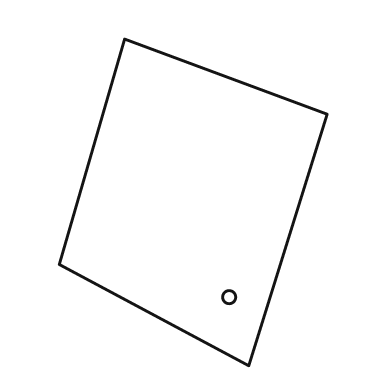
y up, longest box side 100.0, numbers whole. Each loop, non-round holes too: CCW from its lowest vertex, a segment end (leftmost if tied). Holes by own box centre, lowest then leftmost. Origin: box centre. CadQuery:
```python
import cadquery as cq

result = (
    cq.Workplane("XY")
    .moveTo(17.0, -50.0)
    .lineTo(41.0, 27.0)
    .lineTo(-21.0, 50.0)
    .lineTo(-41.0, -19.0)
    .close()
    .moveTo(11.0, -29.0)
    .circle(2.0)
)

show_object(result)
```